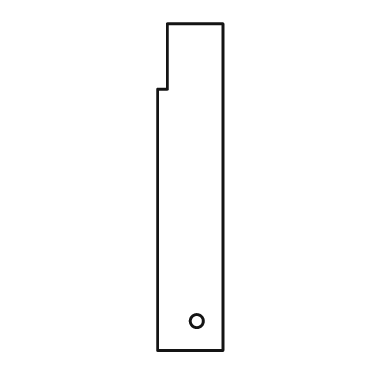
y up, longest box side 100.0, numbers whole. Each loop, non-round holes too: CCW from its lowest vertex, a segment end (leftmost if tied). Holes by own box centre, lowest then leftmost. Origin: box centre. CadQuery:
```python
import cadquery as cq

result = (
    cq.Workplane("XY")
    .moveTo(-10.0, -50.0)
    .lineTo(10.0, -50.0)
    .lineTo(10.0, 50.0)
    .lineTo(-7.0, 50.0)
    .lineTo(-7.0, 30.0)
    .lineTo(-10.0, 30.0)
    .close()
    .moveTo(2.0, -41.0)
    .circle(2.0)
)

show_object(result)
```